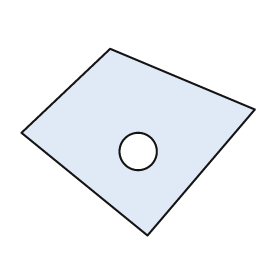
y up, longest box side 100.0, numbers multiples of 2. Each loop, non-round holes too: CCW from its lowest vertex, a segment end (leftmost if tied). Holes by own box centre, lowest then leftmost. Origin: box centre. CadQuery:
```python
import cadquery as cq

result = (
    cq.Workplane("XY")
    .moveTo(4.0, -40.0)
    .lineTo(50.0, 14.0)
    .lineTo(-12.0, 40.0)
    .lineTo(-50.0, 4.0)
    .close()
    .moveTo(0.0, -4.0)
    .circle(8.0)
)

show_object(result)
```